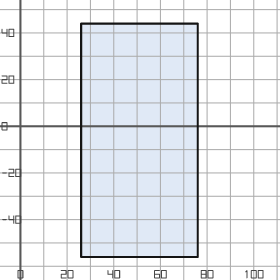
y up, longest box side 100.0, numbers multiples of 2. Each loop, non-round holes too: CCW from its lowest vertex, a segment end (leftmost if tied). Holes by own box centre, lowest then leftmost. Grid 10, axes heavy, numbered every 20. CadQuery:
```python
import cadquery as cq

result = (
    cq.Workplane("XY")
    .moveTo(26.0, -56.0)
    .lineTo(76.0, -56.0)
    .lineTo(76.0, 44.0)
    .lineTo(26.0, 44.0)
    .close()
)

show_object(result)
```